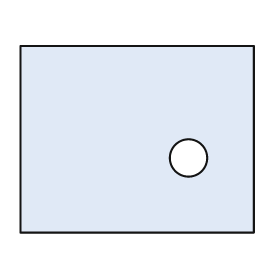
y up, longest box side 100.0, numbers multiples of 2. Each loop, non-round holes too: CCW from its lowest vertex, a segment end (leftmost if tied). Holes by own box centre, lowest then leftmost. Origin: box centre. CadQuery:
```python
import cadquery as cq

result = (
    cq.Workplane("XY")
    .moveTo(-50.0, -40.0)
    .lineTo(50.0, -40.0)
    .lineTo(50.0, 40.0)
    .lineTo(-50.0, 40.0)
    .close()
    .moveTo(22.0, -8.0)
    .circle(8.0)
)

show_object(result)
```